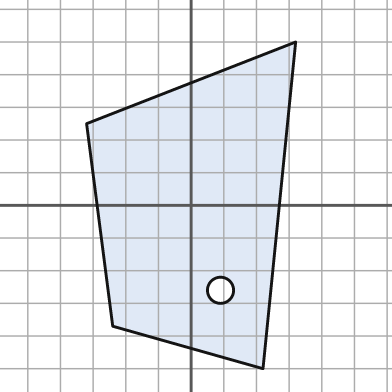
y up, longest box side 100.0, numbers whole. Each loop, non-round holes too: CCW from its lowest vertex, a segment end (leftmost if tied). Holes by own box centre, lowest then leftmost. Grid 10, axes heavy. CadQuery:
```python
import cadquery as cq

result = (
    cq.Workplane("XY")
    .moveTo(22.0, -50.0)
    .lineTo(32.0, 50.0)
    .lineTo(-32.0, 25.0)
    .lineTo(-24.0, -37.0)
    .close()
    .moveTo(9.0, -26.0)
    .circle(4.0)
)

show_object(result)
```